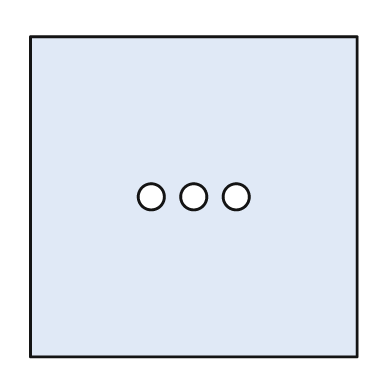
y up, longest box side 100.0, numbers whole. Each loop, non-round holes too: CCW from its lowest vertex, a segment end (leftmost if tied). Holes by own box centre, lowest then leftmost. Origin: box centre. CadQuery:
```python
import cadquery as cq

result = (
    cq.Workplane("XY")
    .moveTo(-50.0, -49.0)
    .lineTo(50.0, -49.0)
    .lineTo(50.0, 49.0)
    .lineTo(-50.0, 49.0)
    .close()
    .moveTo(-13.0, 0.0)
    .circle(4.0)
    .moveTo(0.0, 0.0)
    .circle(4.0)
    .moveTo(13.0, 0.0)
    .circle(4.0)
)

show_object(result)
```